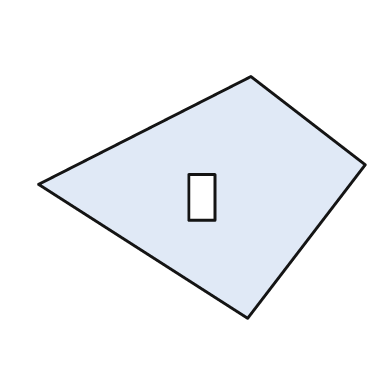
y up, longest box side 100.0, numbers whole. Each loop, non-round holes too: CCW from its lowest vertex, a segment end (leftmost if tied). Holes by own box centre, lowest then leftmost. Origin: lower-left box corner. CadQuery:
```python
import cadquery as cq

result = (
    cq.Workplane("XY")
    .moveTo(64.0, 0.0)
    .lineTo(100.0, 47.0)
    .lineTo(65.0, 74.0)
    .lineTo(0.0, 41.0)
    .close()
    .moveTo(46.0, 30.0)
    .lineTo(54.0, 30.0)
    .lineTo(54.0, 44.0)
    .lineTo(46.0, 44.0)
    .close()
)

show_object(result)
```